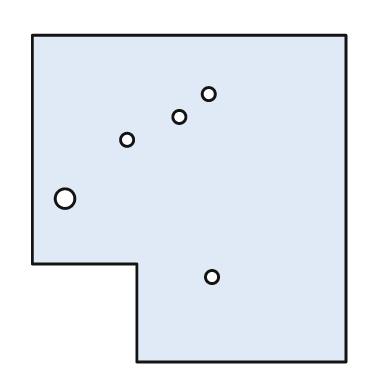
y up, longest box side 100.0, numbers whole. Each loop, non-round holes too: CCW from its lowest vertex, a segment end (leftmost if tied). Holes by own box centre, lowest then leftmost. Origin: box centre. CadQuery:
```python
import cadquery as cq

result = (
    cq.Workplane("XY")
    .moveTo(-16.0, -50.0)
    .lineTo(48.0, -50.0)
    .lineTo(48.0, 50.0)
    .lineTo(-48.0, 50.0)
    .lineTo(-48.0, -20.0)
    .lineTo(-16.0, -20.0)
    .close()
    .moveTo(7.0, -24.0)
    .circle(2.0)
    .moveTo(-38.0, 0.0)
    .circle(3.0)
    .moveTo(-19.0, 18.0)
    .circle(2.0)
    .moveTo(-3.0, 25.0)
    .circle(2.0)
    .moveTo(6.0, 32.0)
    .circle(2.0)
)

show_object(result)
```